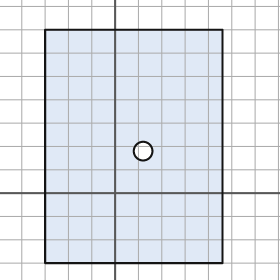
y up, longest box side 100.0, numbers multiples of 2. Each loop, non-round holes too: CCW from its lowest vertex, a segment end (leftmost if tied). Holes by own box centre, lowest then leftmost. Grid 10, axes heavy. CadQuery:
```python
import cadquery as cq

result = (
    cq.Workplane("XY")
    .moveTo(-30.0, -30.0)
    .lineTo(46.0, -30.0)
    .lineTo(46.0, 70.0)
    .lineTo(-30.0, 70.0)
    .close()
    .moveTo(12.0, 18.0)
    .circle(4.0)
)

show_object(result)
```